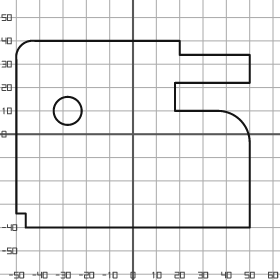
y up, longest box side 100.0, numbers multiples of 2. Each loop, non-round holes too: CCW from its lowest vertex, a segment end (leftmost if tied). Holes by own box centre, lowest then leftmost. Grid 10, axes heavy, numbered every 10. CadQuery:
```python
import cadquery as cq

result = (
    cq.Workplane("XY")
    .moveTo(-46.0, -40.0)
    .lineTo(50.0, -40.0)
    .lineTo(50.0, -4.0)
    .threePointArc((46.0, 6.0), (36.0, 10.0))
    .lineTo(18.0, 10.0)
    .lineTo(18.0, 22.0)
    .lineTo(50.0, 22.0)
    .lineTo(50.0, 34.0)
    .lineTo(20.0, 34.0)
    .lineTo(20.0, 40.0)
    .lineTo(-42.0, 40.0)
    .threePointArc((-48.0, 38.0), (-50.0, 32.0))
    .lineTo(-50.0, -34.0)
    .lineTo(-46.0, -34.0)
    .close()
    .moveTo(-28.0, 10.0)
    .circle(6.0)
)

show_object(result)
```